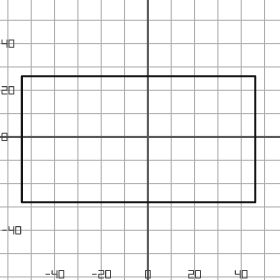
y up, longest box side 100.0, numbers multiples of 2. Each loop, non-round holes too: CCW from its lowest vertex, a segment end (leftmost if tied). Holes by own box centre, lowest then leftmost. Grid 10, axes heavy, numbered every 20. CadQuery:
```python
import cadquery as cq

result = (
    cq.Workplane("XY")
    .moveTo(-54.0, -28.0)
    .lineTo(46.0, -28.0)
    .lineTo(46.0, 26.0)
    .lineTo(-54.0, 26.0)
    .close()
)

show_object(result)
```